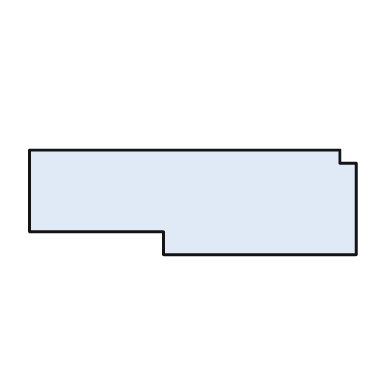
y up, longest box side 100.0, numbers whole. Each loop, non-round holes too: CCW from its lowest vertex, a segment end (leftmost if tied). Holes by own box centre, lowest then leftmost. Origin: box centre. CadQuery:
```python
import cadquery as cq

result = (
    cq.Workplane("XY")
    .moveTo(-9.0, -16.0)
    .lineTo(50.0, -16.0)
    .lineTo(50.0, 12.0)
    .lineTo(45.0, 12.0)
    .lineTo(45.0, 16.0)
    .lineTo(-50.0, 16.0)
    .lineTo(-50.0, -9.0)
    .lineTo(-9.0, -9.0)
    .close()
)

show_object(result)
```